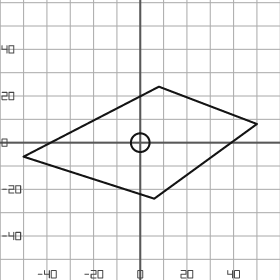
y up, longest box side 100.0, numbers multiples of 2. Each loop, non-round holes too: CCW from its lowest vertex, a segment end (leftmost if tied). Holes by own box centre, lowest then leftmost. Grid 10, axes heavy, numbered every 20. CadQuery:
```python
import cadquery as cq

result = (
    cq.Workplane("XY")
    .moveTo(6.0, -24.0)
    .lineTo(50.0, 8.0)
    .lineTo(8.0, 24.0)
    .lineTo(-50.0, -6.0)
    .close()
    .moveTo(0.0, 0.0)
    .circle(4.0)
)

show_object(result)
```